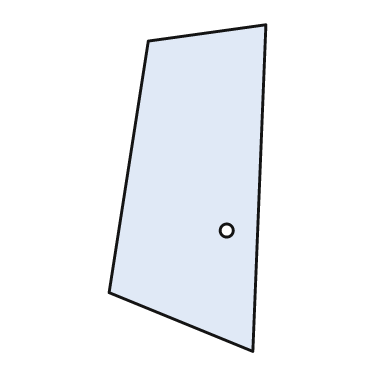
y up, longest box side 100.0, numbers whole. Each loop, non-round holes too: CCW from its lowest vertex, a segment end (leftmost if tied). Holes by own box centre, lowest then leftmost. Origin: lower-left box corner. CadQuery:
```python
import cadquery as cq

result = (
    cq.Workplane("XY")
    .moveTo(44.0, 0.0)
    .lineTo(48.0, 100.0)
    .lineTo(12.0, 95.0)
    .lineTo(0.0, 18.0)
    .close()
    .moveTo(36.0, 37.0)
    .circle(2.0)
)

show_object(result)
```